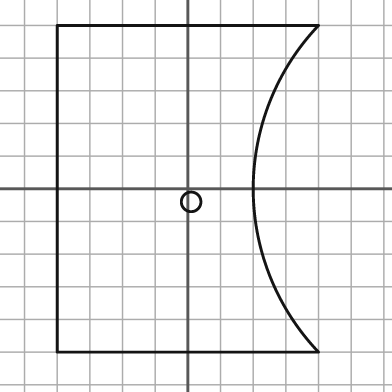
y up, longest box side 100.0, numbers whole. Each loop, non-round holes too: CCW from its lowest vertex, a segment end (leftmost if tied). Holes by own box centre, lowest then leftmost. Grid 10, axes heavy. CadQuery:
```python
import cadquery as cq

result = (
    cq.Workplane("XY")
    .moveTo(-40.0, -50.0)
    .lineTo(40.0, -50.0)
    .threePointArc((20.0, 0.0), (40.0, 50.0))
    .lineTo(-40.0, 50.0)
    .close()
    .moveTo(1.0, -4.0)
    .circle(3.0)
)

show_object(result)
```